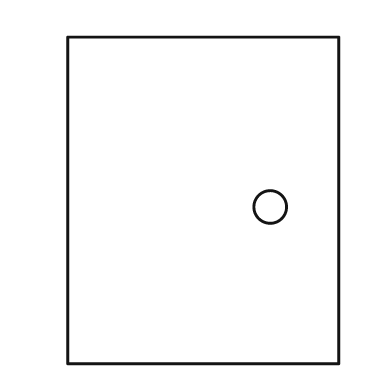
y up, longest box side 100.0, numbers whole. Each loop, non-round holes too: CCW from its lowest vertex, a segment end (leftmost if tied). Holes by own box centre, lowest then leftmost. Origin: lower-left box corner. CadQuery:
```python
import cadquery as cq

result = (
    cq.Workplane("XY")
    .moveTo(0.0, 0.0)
    .lineTo(83.0, 0.0)
    .lineTo(83.0, 100.0)
    .lineTo(0.0, 100.0)
    .close()
    .moveTo(62.0, 48.0)
    .circle(5.0)
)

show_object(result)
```